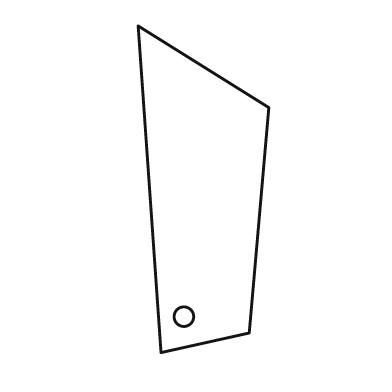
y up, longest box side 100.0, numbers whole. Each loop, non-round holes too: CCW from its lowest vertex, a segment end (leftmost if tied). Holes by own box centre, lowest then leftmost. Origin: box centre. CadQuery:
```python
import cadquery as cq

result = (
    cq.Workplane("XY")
    .moveTo(-13.0, -50.0)
    .lineTo(14.0, -44.0)
    .lineTo(20.0, 25.0)
    .lineTo(-20.0, 50.0)
    .close()
    .moveTo(-6.0, -39.0)
    .circle(3.0)
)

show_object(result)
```